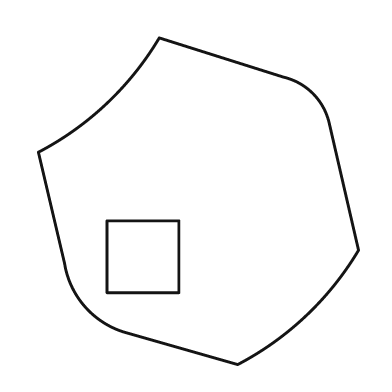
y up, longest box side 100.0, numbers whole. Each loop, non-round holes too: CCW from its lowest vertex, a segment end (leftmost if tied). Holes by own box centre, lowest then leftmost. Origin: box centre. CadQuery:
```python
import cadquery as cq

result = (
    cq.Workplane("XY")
    .moveTo(12.0, -50.0)
    .threePointArc((33.0, -35.0), (49.0, -15.0))
    .lineTo(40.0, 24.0)
    .threePointArc((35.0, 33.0), (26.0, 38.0))
    .lineTo(-12.0, 50.0)
    .threePointArc((-28.0, 30.0), (-49.0, 15.0))
    .lineTo(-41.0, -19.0)
    .threePointArc((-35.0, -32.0), (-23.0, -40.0))
    .close()
    .moveTo(-28.0, -28.0)
    .lineTo(-6.0, -28.0)
    .lineTo(-6.0, -6.0)
    .lineTo(-28.0, -6.0)
    .close()
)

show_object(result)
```